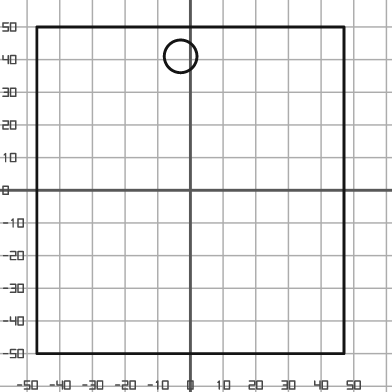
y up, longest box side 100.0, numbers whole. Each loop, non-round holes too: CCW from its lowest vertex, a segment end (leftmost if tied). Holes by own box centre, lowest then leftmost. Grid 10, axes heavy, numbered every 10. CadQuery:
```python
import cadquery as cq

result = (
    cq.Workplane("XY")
    .moveTo(-47.0, -50.0)
    .lineTo(47.0, -50.0)
    .lineTo(47.0, 50.0)
    .lineTo(-47.0, 50.0)
    .close()
    .moveTo(-3.0, 41.0)
    .circle(5.0)
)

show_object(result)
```